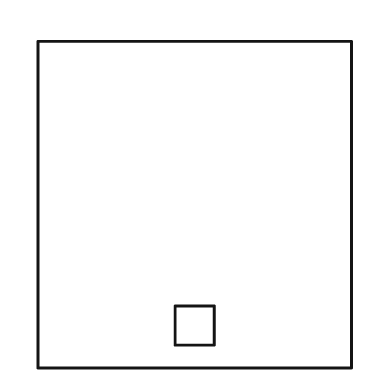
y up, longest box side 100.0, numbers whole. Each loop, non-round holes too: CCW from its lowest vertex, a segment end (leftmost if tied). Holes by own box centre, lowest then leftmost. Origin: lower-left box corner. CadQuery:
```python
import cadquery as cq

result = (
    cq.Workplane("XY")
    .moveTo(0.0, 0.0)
    .lineTo(96.0, 0.0)
    .lineTo(96.0, 100.0)
    .lineTo(0.0, 100.0)
    .close()
    .moveTo(42.0, 7.0)
    .lineTo(54.0, 7.0)
    .lineTo(54.0, 19.0)
    .lineTo(42.0, 19.0)
    .close()
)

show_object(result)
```